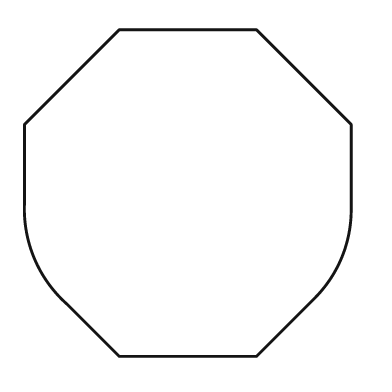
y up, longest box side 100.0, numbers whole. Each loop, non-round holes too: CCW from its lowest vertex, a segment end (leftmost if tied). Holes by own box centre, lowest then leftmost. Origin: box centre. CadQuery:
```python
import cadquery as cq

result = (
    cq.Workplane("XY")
    .moveTo(-21.0, -50.0)
    .lineTo(21.0, -50.0)
    .lineTo(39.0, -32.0)
    .threePointArc((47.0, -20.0), (50.0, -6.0))
    .lineTo(50.0, 21.0)
    .lineTo(21.0, 50.0)
    .lineTo(-21.0, 50.0)
    .lineTo(-50.0, 21.0)
    .lineTo(-50.0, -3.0)
    .threePointArc((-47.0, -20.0), (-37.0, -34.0))
    .close()
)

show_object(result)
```